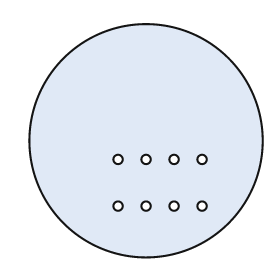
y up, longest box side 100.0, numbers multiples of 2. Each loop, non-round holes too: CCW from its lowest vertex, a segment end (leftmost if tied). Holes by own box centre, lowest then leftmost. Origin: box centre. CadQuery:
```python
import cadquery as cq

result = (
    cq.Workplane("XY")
    .moveTo(0.0, 0.0)
    .circle(50.0)
    .moveTo(-12.0, -28.0)
    .circle(2.0)
    .moveTo(0.0, -28.0)
    .circle(2.0)
    .moveTo(12.0, -28.0)
    .circle(2.0)
    .moveTo(24.0, -28.0)
    .circle(2.0)
    .moveTo(-12.0, -8.0)
    .circle(2.0)
    .moveTo(0.0, -8.0)
    .circle(2.0)
    .moveTo(12.0, -8.0)
    .circle(2.0)
    .moveTo(24.0, -8.0)
    .circle(2.0)
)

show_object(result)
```